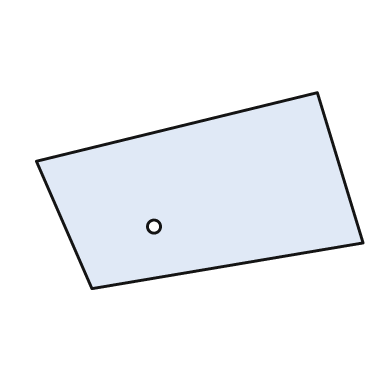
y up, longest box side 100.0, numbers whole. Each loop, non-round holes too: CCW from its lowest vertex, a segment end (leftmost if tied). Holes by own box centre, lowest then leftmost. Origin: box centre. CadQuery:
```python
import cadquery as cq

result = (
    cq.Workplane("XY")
    .moveTo(-33.0, -30.0)
    .lineTo(50.0, -16.0)
    .lineTo(36.0, 30.0)
    .lineTo(-50.0, 9.0)
    .close()
    .moveTo(-14.0, -11.0)
    .circle(2.0)
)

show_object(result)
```